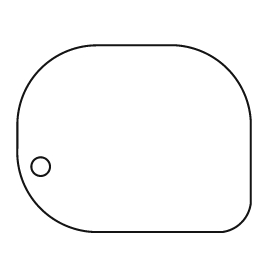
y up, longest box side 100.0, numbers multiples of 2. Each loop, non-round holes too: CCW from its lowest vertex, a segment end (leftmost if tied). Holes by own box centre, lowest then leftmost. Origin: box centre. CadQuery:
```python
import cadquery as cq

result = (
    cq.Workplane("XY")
    .moveTo(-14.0, -40.0)
    .lineTo(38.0, -40.0)
    .threePointArc((46.0, -36.0), (50.0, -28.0))
    .lineTo(50.0, 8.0)
    .threePointArc((40.0, 30.0), (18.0, 40.0))
    .lineTo(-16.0, 40.0)
    .threePointArc((-40.0, 30.0), (-50.0, 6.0))
    .lineTo(-50.0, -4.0)
    .threePointArc((-40.0, -30.0), (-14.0, -40.0))
    .close()
    .moveTo(-40.0, -12.0)
    .circle(4.0)
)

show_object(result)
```